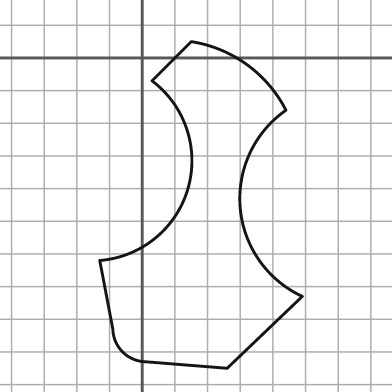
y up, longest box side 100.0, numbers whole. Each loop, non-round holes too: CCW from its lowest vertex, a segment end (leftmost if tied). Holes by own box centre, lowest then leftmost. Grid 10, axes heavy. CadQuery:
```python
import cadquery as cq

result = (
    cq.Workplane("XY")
    .moveTo(26.0, -95.0)
    .lineTo(49.0, -73.0)
    .threePointArc((30.0, -46.0), (44.0, -16.0))
    .threePointArc((32.0, -2.0), (15.0, 5.0))
    .lineTo(3.0, -7.0)
    .threePointArc((14.0, -40.0), (-13.0, -62.0))
    .lineTo(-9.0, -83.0)
    .threePointArc((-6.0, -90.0), (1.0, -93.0))
    .close()
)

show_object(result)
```